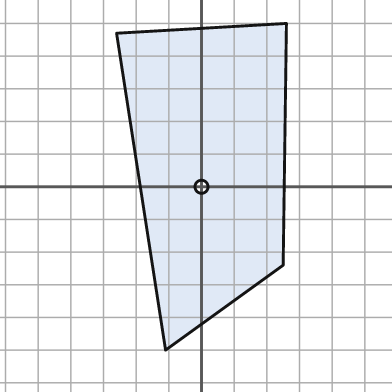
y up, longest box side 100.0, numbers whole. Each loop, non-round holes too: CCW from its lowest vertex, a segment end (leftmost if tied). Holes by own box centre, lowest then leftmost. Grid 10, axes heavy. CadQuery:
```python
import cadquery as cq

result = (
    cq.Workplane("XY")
    .moveTo(-11.0, -50.0)
    .lineTo(25.0, -24.0)
    .lineTo(26.0, 50.0)
    .lineTo(-26.0, 47.0)
    .close()
    .moveTo(0.0, 0.0)
    .circle(2.0)
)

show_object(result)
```